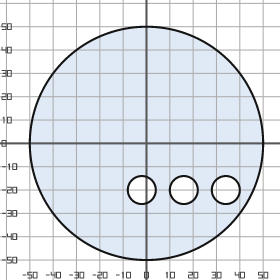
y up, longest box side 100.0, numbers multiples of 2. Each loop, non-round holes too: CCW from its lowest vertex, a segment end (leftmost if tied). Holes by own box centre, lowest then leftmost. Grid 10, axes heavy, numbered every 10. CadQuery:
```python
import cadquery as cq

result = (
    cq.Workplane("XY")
    .moveTo(0.0, 0.0)
    .circle(50.0)
    .moveTo(-2.0, -20.0)
    .circle(6.0)
    .moveTo(16.0, -20.0)
    .circle(6.0)
    .moveTo(34.0, -20.0)
    .circle(6.0)
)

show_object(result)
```